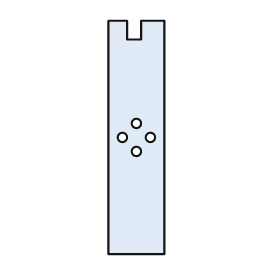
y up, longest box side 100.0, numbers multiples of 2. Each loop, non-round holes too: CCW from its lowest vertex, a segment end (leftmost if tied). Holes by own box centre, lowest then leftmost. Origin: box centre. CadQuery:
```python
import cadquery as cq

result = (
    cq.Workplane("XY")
    .moveTo(-12.0, -50.0)
    .lineTo(12.0, -50.0)
    .lineTo(12.0, 50.0)
    .lineTo(2.0, 50.0)
    .lineTo(2.0, 42.0)
    .lineTo(-4.0, 42.0)
    .lineTo(-4.0, 50.0)
    .lineTo(-12.0, 50.0)
    .close()
    .moveTo(0.0, -6.0)
    .circle(2.0)
    .moveTo(-6.0, 0.0)
    .circle(2.0)
    .moveTo(6.0, 0.0)
    .circle(2.0)
    .moveTo(0.0, 6.0)
    .circle(2.0)
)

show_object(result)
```